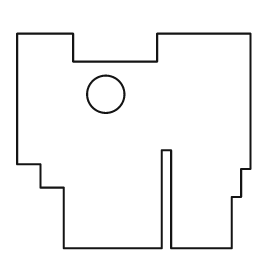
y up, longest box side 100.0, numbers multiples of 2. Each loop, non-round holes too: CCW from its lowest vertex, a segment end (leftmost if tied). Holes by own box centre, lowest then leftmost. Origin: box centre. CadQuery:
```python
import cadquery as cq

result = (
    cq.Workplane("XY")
    .moveTo(-30.0, -46.0)
    .lineTo(12.0, -46.0)
    .lineTo(12.0, -4.0)
    .lineTo(16.0, -4.0)
    .lineTo(16.0, -46.0)
    .lineTo(42.0, -46.0)
    .lineTo(42.0, -24.0)
    .lineTo(46.0, -24.0)
    .lineTo(46.0, -12.0)
    .lineTo(50.0, -12.0)
    .lineTo(50.0, 46.0)
    .lineTo(10.0, 46.0)
    .lineTo(10.0, 34.0)
    .lineTo(-26.0, 34.0)
    .lineTo(-26.0, 46.0)
    .lineTo(-50.0, 46.0)
    .lineTo(-50.0, -10.0)
    .lineTo(-40.0, -10.0)
    .lineTo(-40.0, -20.0)
    .lineTo(-30.0, -20.0)
    .close()
    .moveTo(-12.0, 20.0)
    .circle(8.0)
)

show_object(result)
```